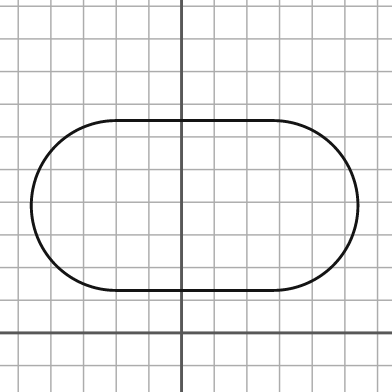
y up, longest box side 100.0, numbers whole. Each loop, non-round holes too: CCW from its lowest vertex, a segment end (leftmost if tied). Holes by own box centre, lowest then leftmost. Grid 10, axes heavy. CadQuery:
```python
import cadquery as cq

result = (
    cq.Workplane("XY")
    .moveTo(-20.0, 13.0)
    .lineTo(28.0, 13.0)
    .threePointArc((54.0, 39.0), (28.0, 65.0))
    .lineTo(-20.0, 65.0)
    .threePointArc((-46.0, 39.0), (-20.0, 13.0))
    .close()
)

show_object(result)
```